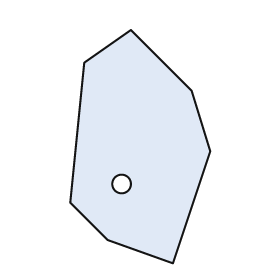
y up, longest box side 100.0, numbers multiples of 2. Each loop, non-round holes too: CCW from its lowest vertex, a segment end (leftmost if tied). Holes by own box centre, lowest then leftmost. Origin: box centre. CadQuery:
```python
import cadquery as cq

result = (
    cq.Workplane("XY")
    .moveTo(14.0, -50.0)
    .lineTo(30.0, -2.0)
    .lineTo(22.0, 24.0)
    .lineTo(-4.0, 50.0)
    .lineTo(-24.0, 36.0)
    .lineTo(-30.0, -24.0)
    .lineTo(-14.0, -40.0)
    .close()
    .moveTo(-8.0, -16.0)
    .circle(4.0)
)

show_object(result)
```